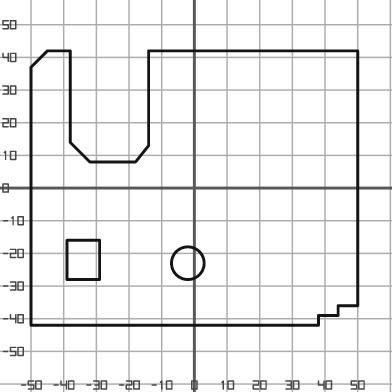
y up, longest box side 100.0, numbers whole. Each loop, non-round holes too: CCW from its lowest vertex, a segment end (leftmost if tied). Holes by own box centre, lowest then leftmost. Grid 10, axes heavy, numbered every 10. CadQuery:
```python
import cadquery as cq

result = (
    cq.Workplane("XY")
    .moveTo(-50.0, -42.0)
    .lineTo(38.0, -42.0)
    .lineTo(38.0, -39.0)
    .lineTo(44.0, -39.0)
    .lineTo(44.0, -36.0)
    .lineTo(50.0, -36.0)
    .lineTo(50.0, 42.0)
    .lineTo(-14.0, 42.0)
    .lineTo(-14.0, 13.0)
    .lineTo(-18.0, 8.0)
    .lineTo(-32.0, 8.0)
    .lineTo(-38.0, 14.0)
    .lineTo(-38.0, 42.0)
    .lineTo(-45.0, 42.0)
    .lineTo(-50.0, 37.0)
    .close()
    .moveTo(-2.0, -23.0)
    .circle(5.0)
    .moveTo(-39.0, -28.0)
    .lineTo(-29.0, -28.0)
    .lineTo(-29.0, -16.0)
    .lineTo(-39.0, -16.0)
    .close()
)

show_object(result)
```